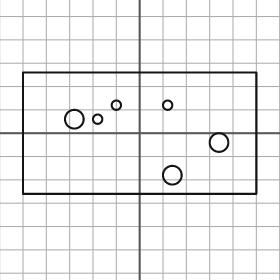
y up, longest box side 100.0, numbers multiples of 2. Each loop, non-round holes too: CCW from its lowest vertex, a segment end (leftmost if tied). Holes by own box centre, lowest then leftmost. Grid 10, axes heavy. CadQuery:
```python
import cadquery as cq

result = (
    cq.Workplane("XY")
    .moveTo(-50.0, -26.0)
    .lineTo(50.0, -26.0)
    .lineTo(50.0, 26.0)
    .lineTo(-50.0, 26.0)
    .close()
    .moveTo(14.0, -18.0)
    .circle(4.0)
    .moveTo(34.0, -4.0)
    .circle(4.0)
    .moveTo(-28.0, 6.0)
    .circle(4.0)
    .moveTo(-18.0, 6.0)
    .circle(2.0)
    .moveTo(-10.0, 12.0)
    .circle(2.0)
    .moveTo(12.0, 12.0)
    .circle(2.0)
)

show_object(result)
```